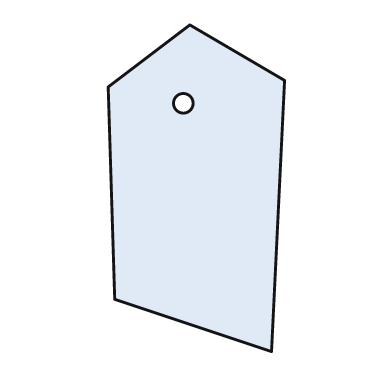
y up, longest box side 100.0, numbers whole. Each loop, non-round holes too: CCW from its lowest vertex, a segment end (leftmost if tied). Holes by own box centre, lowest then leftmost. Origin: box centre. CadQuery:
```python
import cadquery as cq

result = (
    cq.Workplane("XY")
    .moveTo(23.0, -50.0)
    .lineTo(27.0, 33.0)
    .lineTo(-2.0, 50.0)
    .lineTo(-27.0, 31.0)
    .lineTo(-25.0, -34.0)
    .close()
    .moveTo(-4.0, 26.0)
    .circle(3.0)
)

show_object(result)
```